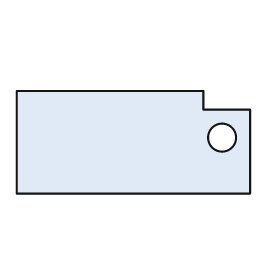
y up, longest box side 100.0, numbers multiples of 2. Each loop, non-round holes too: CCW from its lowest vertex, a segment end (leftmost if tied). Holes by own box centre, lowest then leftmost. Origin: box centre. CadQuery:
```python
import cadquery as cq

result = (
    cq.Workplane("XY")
    .moveTo(-50.0, -22.0)
    .lineTo(50.0, -22.0)
    .lineTo(50.0, 14.0)
    .lineTo(30.0, 14.0)
    .lineTo(30.0, 22.0)
    .lineTo(-50.0, 22.0)
    .close()
    .moveTo(38.0, 2.0)
    .circle(6.0)
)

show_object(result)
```